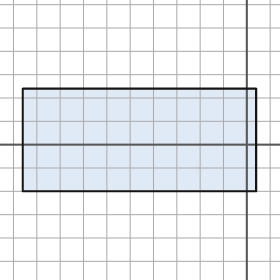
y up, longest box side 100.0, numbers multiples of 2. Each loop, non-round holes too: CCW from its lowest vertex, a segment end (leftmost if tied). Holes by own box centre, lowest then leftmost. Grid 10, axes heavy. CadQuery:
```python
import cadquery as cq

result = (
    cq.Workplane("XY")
    .moveTo(-96.0, -20.0)
    .lineTo(4.0, -20.0)
    .lineTo(4.0, 24.0)
    .lineTo(-96.0, 24.0)
    .close()
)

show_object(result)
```